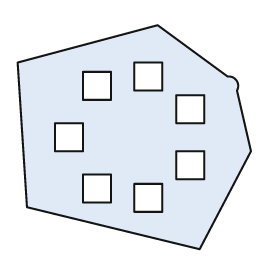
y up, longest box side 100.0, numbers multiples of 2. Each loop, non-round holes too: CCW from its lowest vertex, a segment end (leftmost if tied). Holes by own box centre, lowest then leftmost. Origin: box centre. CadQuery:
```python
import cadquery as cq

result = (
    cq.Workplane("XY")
    .moveTo(28.0, -48.0)
    .lineTo(50.0, -6.0)
    .lineTo(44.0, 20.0)
    .threePointArc((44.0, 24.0), (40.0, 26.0))
    .lineTo(10.0, 48.0)
    .lineTo(-50.0, 32.0)
    .lineTo(-46.0, -30.0)
    .close()
    .moveTo(0.0, -32.0)
    .lineTo(12.0, -32.0)
    .lineTo(12.0, -20.0)
    .lineTo(0.0, -20.0)
    .close()
    .moveTo(-22.0, -28.0)
    .lineTo(-10.0, -28.0)
    .lineTo(-10.0, -16.0)
    .lineTo(-22.0, -16.0)
    .close()
    .moveTo(18.0, -18.0)
    .lineTo(30.0, -18.0)
    .lineTo(30.0, -6.0)
    .lineTo(18.0, -6.0)
    .close()
    .moveTo(-34.0, -6.0)
    .lineTo(-22.0, -6.0)
    .lineTo(-22.0, 6.0)
    .lineTo(-34.0, 6.0)
    .close()
    .moveTo(18.0, 6.0)
    .lineTo(30.0, 6.0)
    .lineTo(30.0, 18.0)
    .lineTo(18.0, 18.0)
    .close()
    .moveTo(-22.0, 16.0)
    .lineTo(-10.0, 16.0)
    .lineTo(-10.0, 28.0)
    .lineTo(-22.0, 28.0)
    .close()
    .moveTo(0.0, 20.0)
    .lineTo(12.0, 20.0)
    .lineTo(12.0, 32.0)
    .lineTo(0.0, 32.0)
    .close()
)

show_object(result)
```